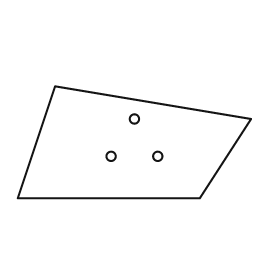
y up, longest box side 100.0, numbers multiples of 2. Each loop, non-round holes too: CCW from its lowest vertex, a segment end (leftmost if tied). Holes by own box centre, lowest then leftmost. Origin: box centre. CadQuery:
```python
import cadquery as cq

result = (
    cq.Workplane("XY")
    .moveTo(-50.0, -24.0)
    .lineTo(28.0, -24.0)
    .lineTo(50.0, 10.0)
    .lineTo(-34.0, 24.0)
    .close()
    .moveTo(-10.0, -6.0)
    .circle(2.0)
    .moveTo(10.0, -6.0)
    .circle(2.0)
    .moveTo(0.0, 10.0)
    .circle(2.0)
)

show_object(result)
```